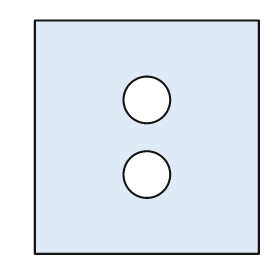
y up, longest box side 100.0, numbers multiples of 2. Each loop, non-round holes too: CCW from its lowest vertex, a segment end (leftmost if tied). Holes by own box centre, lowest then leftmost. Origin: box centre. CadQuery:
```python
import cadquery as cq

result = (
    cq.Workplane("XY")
    .moveTo(-48.0, -50.0)
    .lineTo(48.0, -50.0)
    .lineTo(48.0, 50.0)
    .lineTo(-48.0, 50.0)
    .close()
    .moveTo(0.0, -16.0)
    .circle(10.0)
    .moveTo(0.0, 16.0)
    .circle(10.0)
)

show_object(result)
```